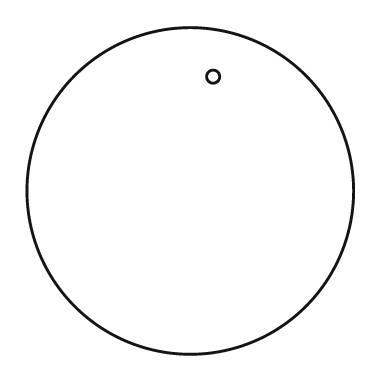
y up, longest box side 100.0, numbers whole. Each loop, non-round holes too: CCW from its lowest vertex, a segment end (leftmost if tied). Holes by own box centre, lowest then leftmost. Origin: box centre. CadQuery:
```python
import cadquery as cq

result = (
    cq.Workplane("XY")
    .moveTo(0.0, 0.0)
    .circle(50.0)
    .moveTo(7.0, 35.0)
    .circle(2.0)
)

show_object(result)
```